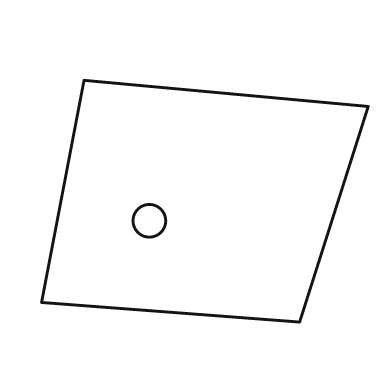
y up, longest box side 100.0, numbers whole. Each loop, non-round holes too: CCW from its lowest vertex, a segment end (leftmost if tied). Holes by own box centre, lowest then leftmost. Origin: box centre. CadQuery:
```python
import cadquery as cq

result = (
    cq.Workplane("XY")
    .moveTo(29.0, -37.0)
    .lineTo(50.0, 29.0)
    .lineTo(-37.0, 37.0)
    .lineTo(-50.0, -31.0)
    .close()
    .moveTo(-17.0, -6.0)
    .circle(5.0)
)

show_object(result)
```